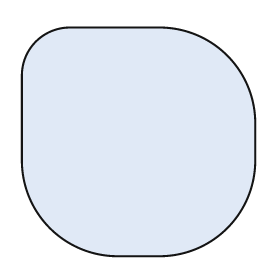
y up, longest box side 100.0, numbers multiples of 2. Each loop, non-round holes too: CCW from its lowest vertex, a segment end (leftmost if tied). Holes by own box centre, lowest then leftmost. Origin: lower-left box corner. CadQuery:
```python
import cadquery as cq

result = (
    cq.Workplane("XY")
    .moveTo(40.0, 0.0)
    .lineTo(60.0, 0.0)
    .threePointArc((88.0, 12.0), (100.0, 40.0))
    .lineTo(100.0, 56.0)
    .threePointArc((88.0, 86.0), (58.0, 98.0))
    .lineTo(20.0, 98.0)
    .threePointArc((6.0, 92.0), (0.0, 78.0))
    .lineTo(0.0, 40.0)
    .threePointArc((12.0, 12.0), (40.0, 0.0))
    .close()
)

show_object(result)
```